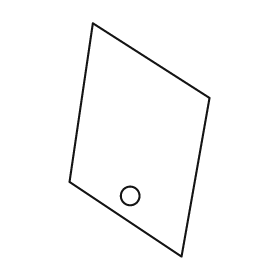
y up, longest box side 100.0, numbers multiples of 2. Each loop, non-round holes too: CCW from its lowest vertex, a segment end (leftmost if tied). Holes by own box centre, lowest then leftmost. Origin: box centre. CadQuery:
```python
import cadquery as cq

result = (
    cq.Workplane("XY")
    .moveTo(18.0, -50.0)
    .lineTo(30.0, 18.0)
    .lineTo(-20.0, 50.0)
    .lineTo(-30.0, -18.0)
    .close()
    .moveTo(-4.0, -24.0)
    .circle(4.0)
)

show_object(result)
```